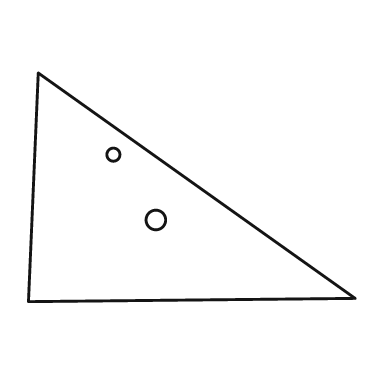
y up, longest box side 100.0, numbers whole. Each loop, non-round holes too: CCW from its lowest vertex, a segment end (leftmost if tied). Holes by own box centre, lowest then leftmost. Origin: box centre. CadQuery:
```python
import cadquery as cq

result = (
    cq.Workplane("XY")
    .moveTo(-50.0, -35.0)
    .lineTo(50.0, -34.0)
    .lineTo(-47.0, 35.0)
    .close()
    .moveTo(-11.0, -10.0)
    .circle(3.0)
    .moveTo(-24.0, 10.0)
    .circle(2.0)
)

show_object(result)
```